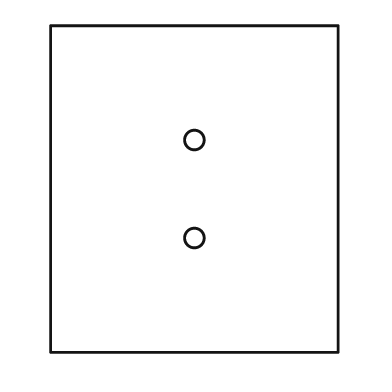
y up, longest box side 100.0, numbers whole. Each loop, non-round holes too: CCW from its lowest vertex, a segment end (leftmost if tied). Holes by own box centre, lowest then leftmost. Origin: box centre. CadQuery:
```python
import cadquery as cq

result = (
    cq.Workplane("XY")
    .moveTo(-44.0, -50.0)
    .lineTo(44.0, -50.0)
    .lineTo(44.0, 50.0)
    .lineTo(-44.0, 50.0)
    .close()
    .moveTo(0.0, -15.0)
    .circle(3.0)
    .moveTo(0.0, 15.0)
    .circle(3.0)
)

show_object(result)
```